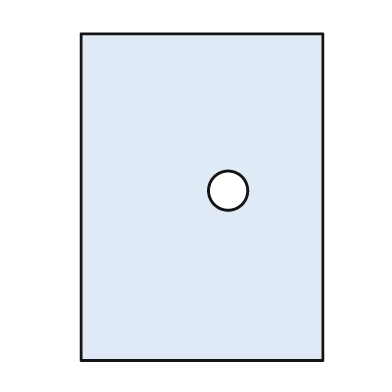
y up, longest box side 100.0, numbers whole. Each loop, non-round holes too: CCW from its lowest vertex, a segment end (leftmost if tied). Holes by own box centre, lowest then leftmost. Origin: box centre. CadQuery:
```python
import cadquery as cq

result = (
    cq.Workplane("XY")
    .moveTo(-37.0, -50.0)
    .lineTo(37.0, -50.0)
    .lineTo(37.0, 50.0)
    .lineTo(-37.0, 50.0)
    .close()
    .moveTo(8.0, 2.0)
    .circle(6.0)
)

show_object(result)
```